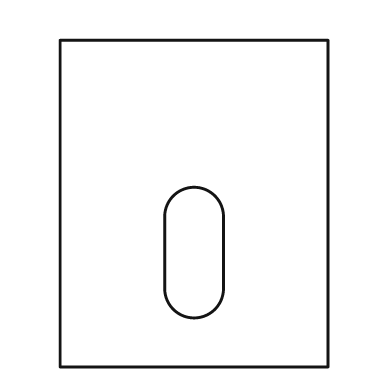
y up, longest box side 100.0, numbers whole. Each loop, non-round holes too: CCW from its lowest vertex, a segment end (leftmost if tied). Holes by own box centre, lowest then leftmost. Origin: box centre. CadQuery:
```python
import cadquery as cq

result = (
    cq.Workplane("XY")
    .moveTo(-41.0, -50.0)
    .lineTo(41.0, -50.0)
    .lineTo(41.0, 50.0)
    .lineTo(-41.0, 50.0)
    .close()
    .moveTo(-9.0, -26.0)
    .threePointArc((0.0, -35.0), (9.0, -26.0))
    .lineTo(9.0, -4.0)
    .threePointArc((0.0, 5.0), (-9.0, -4.0))
    .close()
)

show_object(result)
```